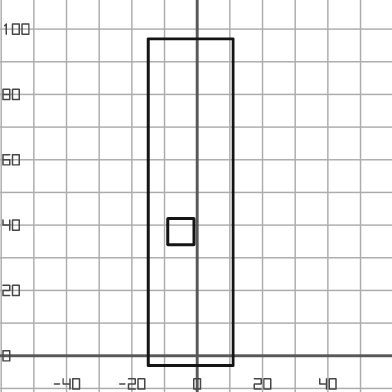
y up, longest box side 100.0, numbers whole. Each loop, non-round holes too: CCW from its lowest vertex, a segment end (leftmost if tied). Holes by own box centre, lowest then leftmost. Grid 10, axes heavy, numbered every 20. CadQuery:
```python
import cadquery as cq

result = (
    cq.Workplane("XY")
    .moveTo(-15.0, -3.0)
    .lineTo(11.0, -3.0)
    .lineTo(11.0, 97.0)
    .lineTo(-15.0, 97.0)
    .close()
    .moveTo(-9.0, 34.0)
    .lineTo(-1.0, 34.0)
    .lineTo(-1.0, 42.0)
    .lineTo(-9.0, 42.0)
    .close()
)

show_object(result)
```